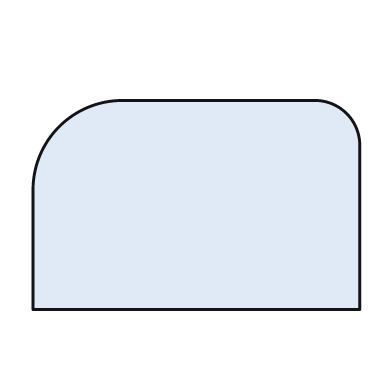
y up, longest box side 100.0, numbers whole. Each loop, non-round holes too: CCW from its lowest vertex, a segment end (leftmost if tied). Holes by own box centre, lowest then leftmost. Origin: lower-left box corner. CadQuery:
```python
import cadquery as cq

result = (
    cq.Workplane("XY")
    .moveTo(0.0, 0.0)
    .lineTo(100.0, 0.0)
    .lineTo(100.0, 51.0)
    .threePointArc((96.0, 60.0), (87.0, 64.0))
    .lineTo(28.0, 64.0)
    .threePointArc((8.0, 56.0), (0.0, 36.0))
    .close()
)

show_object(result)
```